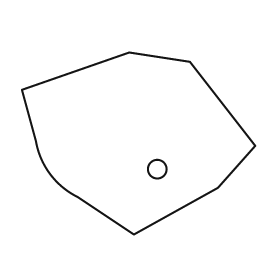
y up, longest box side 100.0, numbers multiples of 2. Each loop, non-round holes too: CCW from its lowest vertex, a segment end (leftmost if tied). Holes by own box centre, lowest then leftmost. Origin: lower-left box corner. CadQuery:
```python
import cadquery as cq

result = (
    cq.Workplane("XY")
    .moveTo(48.0, 0.0)
    .lineTo(84.0, 20.0)
    .lineTo(100.0, 38.0)
    .lineTo(72.0, 74.0)
    .lineTo(46.0, 78.0)
    .lineTo(0.0, 62.0)
    .lineTo(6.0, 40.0)
    .threePointArc((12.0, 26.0), (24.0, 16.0))
    .close()
    .moveTo(58.0, 28.0)
    .circle(4.0)
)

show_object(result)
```